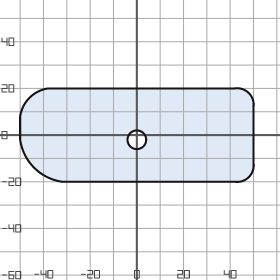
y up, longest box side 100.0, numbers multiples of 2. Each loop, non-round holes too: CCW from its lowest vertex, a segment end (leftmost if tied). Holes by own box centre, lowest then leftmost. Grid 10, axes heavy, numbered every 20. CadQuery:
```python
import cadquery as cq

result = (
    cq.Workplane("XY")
    .moveTo(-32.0, -20.0)
    .lineTo(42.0, -20.0)
    .threePointArc((48.0, -18.0), (50.0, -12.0))
    .lineTo(50.0, 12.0)
    .threePointArc((48.0, 18.0), (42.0, 20.0))
    .lineTo(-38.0, 20.0)
    .threePointArc((-46.0, 16.0), (-50.0, 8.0))
    .lineTo(-50.0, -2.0)
    .threePointArc((-44.0, -14.0), (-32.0, -20.0))
    .close()
    .moveTo(0.0, -2.0)
    .circle(4.0)
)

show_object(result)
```